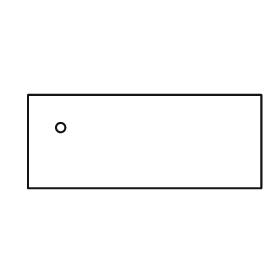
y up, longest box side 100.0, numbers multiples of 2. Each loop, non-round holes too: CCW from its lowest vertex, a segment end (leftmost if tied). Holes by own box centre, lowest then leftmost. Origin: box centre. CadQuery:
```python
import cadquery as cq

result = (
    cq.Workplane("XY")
    .moveTo(-50.0, -20.0)
    .lineTo(50.0, -20.0)
    .lineTo(50.0, 20.0)
    .lineTo(-50.0, 20.0)
    .close()
    .moveTo(-36.0, 6.0)
    .circle(2.0)
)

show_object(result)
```